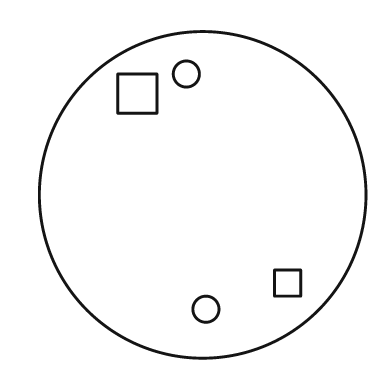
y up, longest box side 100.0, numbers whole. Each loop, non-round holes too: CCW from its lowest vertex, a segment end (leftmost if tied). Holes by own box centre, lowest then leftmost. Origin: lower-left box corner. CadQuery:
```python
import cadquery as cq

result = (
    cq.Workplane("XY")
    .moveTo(50.0, 50.0)
    .circle(50.0)
    .moveTo(51.0, 15.0)
    .circle(4.0)
    .moveTo(72.0, 19.0)
    .lineTo(80.0, 19.0)
    .lineTo(80.0, 27.0)
    .lineTo(72.0, 27.0)
    .close()
    .moveTo(24.0, 75.0)
    .lineTo(36.0, 75.0)
    .lineTo(36.0, 87.0)
    .lineTo(24.0, 87.0)
    .close()
    .moveTo(45.0, 87.0)
    .circle(4.0)
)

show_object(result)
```